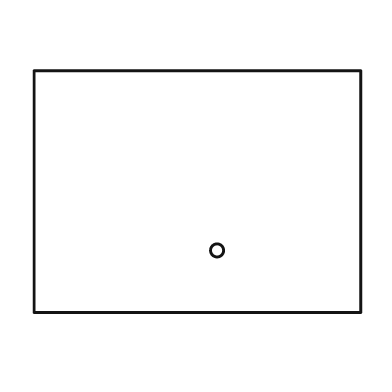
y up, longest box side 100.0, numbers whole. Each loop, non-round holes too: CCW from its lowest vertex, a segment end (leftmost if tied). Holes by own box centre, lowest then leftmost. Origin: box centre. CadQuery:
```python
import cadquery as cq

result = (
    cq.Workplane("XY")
    .moveTo(-50.0, -37.0)
    .lineTo(50.0, -37.0)
    .lineTo(50.0, 37.0)
    .lineTo(-50.0, 37.0)
    .close()
    .moveTo(6.0, -18.0)
    .circle(2.0)
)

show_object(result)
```